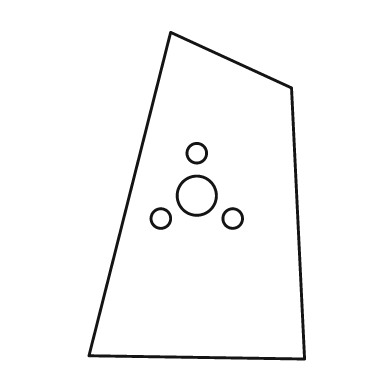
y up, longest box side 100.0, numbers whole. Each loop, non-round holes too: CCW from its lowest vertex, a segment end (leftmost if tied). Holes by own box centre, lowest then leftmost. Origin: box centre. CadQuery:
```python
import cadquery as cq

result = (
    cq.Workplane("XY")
    .moveTo(33.0, -50.0)
    .lineTo(29.0, 33.0)
    .lineTo(-8.0, 50.0)
    .lineTo(-33.0, -49.0)
    .close()
    .moveTo(-11.0, -7.0)
    .circle(3.0)
    .moveTo(11.0, -7.0)
    .circle(3.0)
    .moveTo(0.0, 0.0)
    .circle(6.0)
    .moveTo(0.0, 13.0)
    .circle(3.0)
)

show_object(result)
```